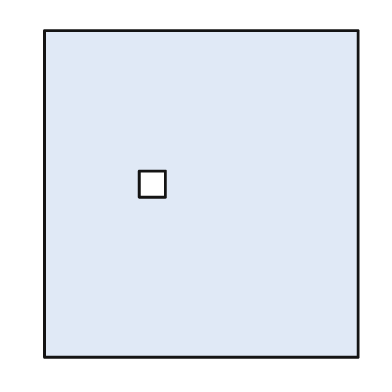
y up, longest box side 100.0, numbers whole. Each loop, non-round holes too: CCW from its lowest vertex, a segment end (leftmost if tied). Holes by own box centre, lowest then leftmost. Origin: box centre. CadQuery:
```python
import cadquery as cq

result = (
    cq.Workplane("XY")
    .moveTo(-48.0, -50.0)
    .lineTo(48.0, -50.0)
    .lineTo(48.0, 50.0)
    .lineTo(-48.0, 50.0)
    .close()
    .moveTo(-19.0, -1.0)
    .lineTo(-11.0, -1.0)
    .lineTo(-11.0, 7.0)
    .lineTo(-19.0, 7.0)
    .close()
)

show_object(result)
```